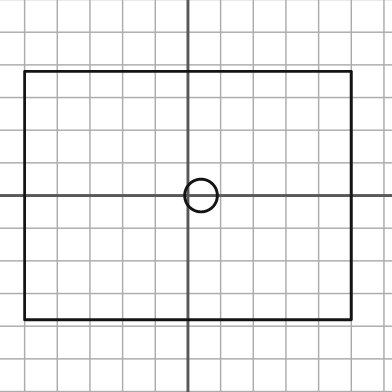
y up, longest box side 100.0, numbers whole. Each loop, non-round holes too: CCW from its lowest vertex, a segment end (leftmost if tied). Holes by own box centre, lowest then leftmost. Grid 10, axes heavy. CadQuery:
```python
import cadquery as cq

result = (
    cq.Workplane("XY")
    .moveTo(-50.0, -38.0)
    .lineTo(50.0, -38.0)
    .lineTo(50.0, 38.0)
    .lineTo(-50.0, 38.0)
    .close()
    .moveTo(4.0, 0.0)
    .circle(5.0)
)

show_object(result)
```